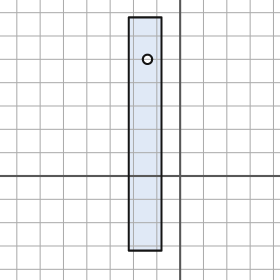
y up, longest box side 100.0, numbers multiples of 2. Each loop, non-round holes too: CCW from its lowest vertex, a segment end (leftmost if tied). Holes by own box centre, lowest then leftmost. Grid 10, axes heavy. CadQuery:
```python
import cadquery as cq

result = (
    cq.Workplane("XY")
    .moveTo(-22.0, -32.0)
    .lineTo(-8.0, -32.0)
    .lineTo(-8.0, 68.0)
    .lineTo(-22.0, 68.0)
    .close()
    .moveTo(-14.0, 50.0)
    .circle(2.0)
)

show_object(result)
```